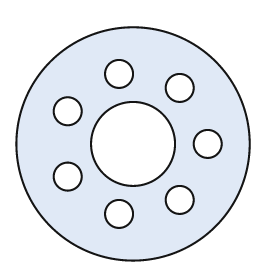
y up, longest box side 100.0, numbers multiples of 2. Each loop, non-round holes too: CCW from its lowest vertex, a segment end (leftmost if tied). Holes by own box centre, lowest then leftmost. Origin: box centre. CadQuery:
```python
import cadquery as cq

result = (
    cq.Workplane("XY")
    .moveTo(0.0, 0.0)
    .circle(50.0)
    .moveTo(-6.0, -30.0)
    .circle(6.0)
    .moveTo(20.0, -24.0)
    .circle(6.0)
    .moveTo(-28.0, -14.0)
    .circle(6.0)
    .moveTo(0.0, 0.0)
    .circle(18.0)
    .moveTo(32.0, 0.0)
    .circle(6.0)
    .moveTo(-28.0, 14.0)
    .circle(6.0)
    .moveTo(20.0, 24.0)
    .circle(6.0)
    .moveTo(-6.0, 30.0)
    .circle(6.0)
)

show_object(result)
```